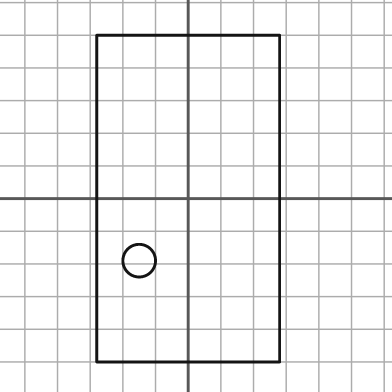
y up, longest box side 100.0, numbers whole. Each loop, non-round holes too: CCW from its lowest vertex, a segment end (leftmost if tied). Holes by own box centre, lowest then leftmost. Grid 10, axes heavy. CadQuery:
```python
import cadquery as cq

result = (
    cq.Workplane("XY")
    .moveTo(-28.0, -50.0)
    .lineTo(28.0, -50.0)
    .lineTo(28.0, 50.0)
    .lineTo(-28.0, 50.0)
    .close()
    .moveTo(-15.0, -19.0)
    .circle(5.0)
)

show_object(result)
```